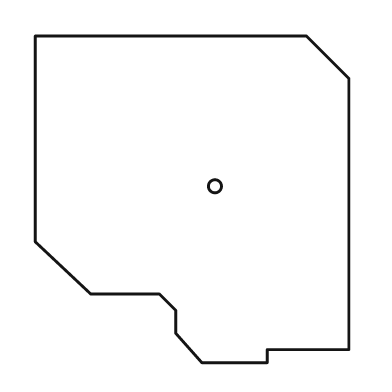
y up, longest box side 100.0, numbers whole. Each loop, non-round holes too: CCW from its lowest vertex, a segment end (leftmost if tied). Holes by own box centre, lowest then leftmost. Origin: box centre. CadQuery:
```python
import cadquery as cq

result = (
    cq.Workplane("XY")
    .moveTo(3.0, -50.0)
    .lineTo(23.0, -50.0)
    .lineTo(23.0, -46.0)
    .lineTo(48.0, -46.0)
    .lineTo(48.0, 37.0)
    .lineTo(35.0, 50.0)
    .lineTo(-48.0, 50.0)
    .lineTo(-48.0, -13.0)
    .lineTo(-31.0, -29.0)
    .lineTo(-10.0, -29.0)
    .lineTo(-5.0, -34.0)
    .lineTo(-5.0, -41.0)
    .close()
    .moveTo(7.0, 4.0)
    .circle(2.0)
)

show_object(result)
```